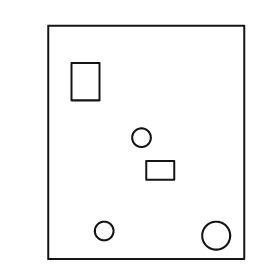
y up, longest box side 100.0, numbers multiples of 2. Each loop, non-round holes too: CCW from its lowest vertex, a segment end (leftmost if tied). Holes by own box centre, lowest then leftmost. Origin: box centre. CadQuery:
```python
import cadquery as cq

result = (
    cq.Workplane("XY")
    .moveTo(-42.0, -50.0)
    .lineTo(42.0, -50.0)
    .lineTo(42.0, 50.0)
    .lineTo(-42.0, 50.0)
    .close()
    .moveTo(30.0, -40.0)
    .circle(6.0)
    .moveTo(-18.0, -38.0)
    .circle(4.0)
    .moveTo(0.0, -16.0)
    .lineTo(12.0, -16.0)
    .lineTo(12.0, -8.0)
    .lineTo(0.0, -8.0)
    .close()
    .moveTo(-2.0, 2.0)
    .circle(4.0)
    .moveTo(-32.0, 18.0)
    .lineTo(-20.0, 18.0)
    .lineTo(-20.0, 34.0)
    .lineTo(-32.0, 34.0)
    .close()
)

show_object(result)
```